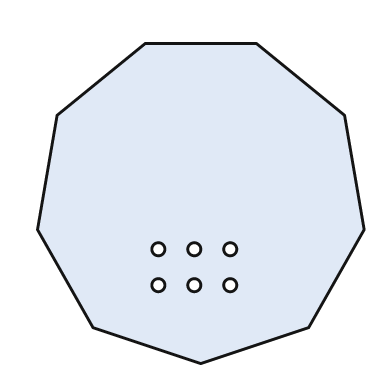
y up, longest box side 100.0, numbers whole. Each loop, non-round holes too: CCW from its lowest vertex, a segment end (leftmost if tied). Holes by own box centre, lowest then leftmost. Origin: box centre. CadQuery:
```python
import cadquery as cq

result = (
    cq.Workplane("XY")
    .moveTo(0.0, -49.0)
    .lineTo(33.0, -38.0)
    .lineTo(50.0, -8.0)
    .lineTo(44.0, 27.0)
    .lineTo(17.0, 49.0)
    .lineTo(-17.0, 49.0)
    .lineTo(-44.0, 27.0)
    .lineTo(-50.0, -8.0)
    .lineTo(-33.0, -38.0)
    .close()
    .moveTo(-13.0, -25.0)
    .circle(2.0)
    .moveTo(-2.0, -25.0)
    .circle(2.0)
    .moveTo(9.0, -25.0)
    .circle(2.0)
    .moveTo(-13.0, -14.0)
    .circle(2.0)
    .moveTo(-2.0, -14.0)
    .circle(2.0)
    .moveTo(9.0, -14.0)
    .circle(2.0)
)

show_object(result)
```